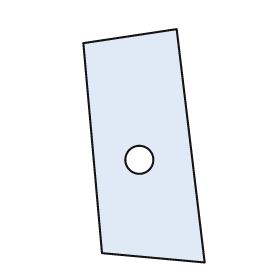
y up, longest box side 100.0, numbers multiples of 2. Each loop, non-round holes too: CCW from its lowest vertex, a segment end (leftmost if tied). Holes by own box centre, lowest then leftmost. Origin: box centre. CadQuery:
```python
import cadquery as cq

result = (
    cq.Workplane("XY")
    .moveTo(26.0, -50.0)
    .lineTo(14.0, 50.0)
    .lineTo(-26.0, 44.0)
    .lineTo(-18.0, -46.0)
    .close()
    .moveTo(-2.0, -6.0)
    .circle(6.0)
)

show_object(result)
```